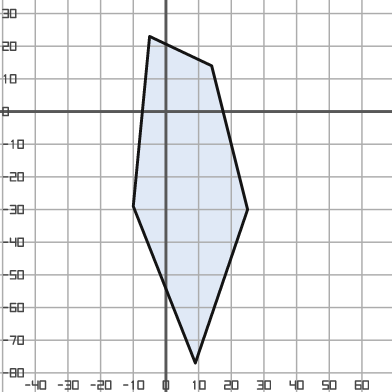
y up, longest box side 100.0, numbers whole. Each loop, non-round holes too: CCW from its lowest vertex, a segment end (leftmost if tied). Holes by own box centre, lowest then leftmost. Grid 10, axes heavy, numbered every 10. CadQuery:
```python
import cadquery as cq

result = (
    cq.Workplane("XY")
    .moveTo(9.0, -77.0)
    .lineTo(25.0, -30.0)
    .lineTo(14.0, 14.0)
    .lineTo(-5.0, 23.0)
    .lineTo(-10.0, -29.0)
    .close()
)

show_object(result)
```